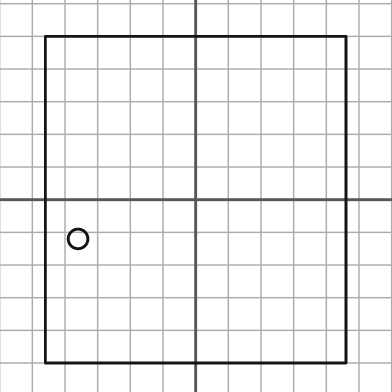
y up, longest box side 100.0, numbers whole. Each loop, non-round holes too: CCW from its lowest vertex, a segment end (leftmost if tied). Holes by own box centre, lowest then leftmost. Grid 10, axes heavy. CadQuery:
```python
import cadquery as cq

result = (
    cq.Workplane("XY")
    .moveTo(-46.0, -50.0)
    .lineTo(46.0, -50.0)
    .lineTo(46.0, 50.0)
    .lineTo(-46.0, 50.0)
    .close()
    .moveTo(-36.0, -12.0)
    .circle(3.0)
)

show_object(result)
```